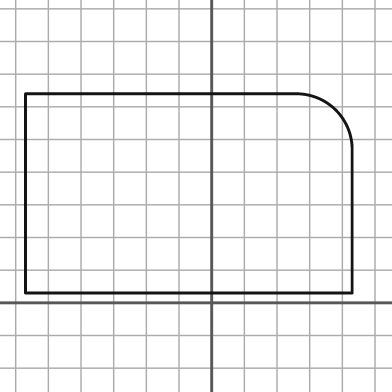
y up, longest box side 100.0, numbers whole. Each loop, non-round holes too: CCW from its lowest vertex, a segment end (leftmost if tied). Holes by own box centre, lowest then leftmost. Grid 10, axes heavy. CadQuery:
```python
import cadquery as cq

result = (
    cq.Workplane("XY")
    .moveTo(-57.0, 3.0)
    .lineTo(43.0, 3.0)
    .lineTo(43.0, 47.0)
    .threePointArc((38.0, 59.0), (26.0, 64.0))
    .lineTo(-57.0, 64.0)
    .close()
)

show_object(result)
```